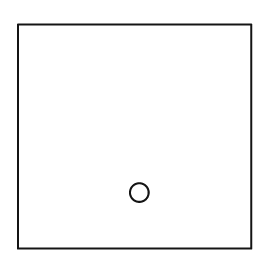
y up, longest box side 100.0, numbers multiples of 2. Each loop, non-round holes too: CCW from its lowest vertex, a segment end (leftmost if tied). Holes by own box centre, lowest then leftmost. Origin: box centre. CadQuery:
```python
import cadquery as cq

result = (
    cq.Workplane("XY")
    .moveTo(-50.0, -48.0)
    .lineTo(50.0, -48.0)
    .lineTo(50.0, 48.0)
    .lineTo(-50.0, 48.0)
    .close()
    .moveTo(2.0, -24.0)
    .circle(4.0)
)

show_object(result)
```